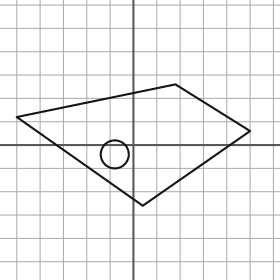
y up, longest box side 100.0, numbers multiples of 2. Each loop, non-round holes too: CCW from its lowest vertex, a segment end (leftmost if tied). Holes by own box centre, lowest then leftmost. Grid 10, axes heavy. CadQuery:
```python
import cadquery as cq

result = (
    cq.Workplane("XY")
    .moveTo(4.0, -26.0)
    .lineTo(50.0, 6.0)
    .lineTo(18.0, 26.0)
    .lineTo(-50.0, 12.0)
    .close()
    .moveTo(-8.0, -4.0)
    .circle(6.0)
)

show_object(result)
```